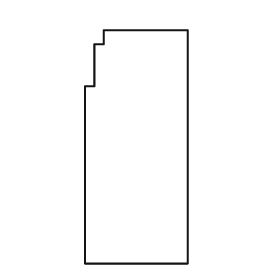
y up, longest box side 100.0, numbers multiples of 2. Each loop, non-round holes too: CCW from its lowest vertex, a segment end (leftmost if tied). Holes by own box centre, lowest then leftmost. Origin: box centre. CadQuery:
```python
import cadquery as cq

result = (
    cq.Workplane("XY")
    .moveTo(-22.0, -50.0)
    .lineTo(22.0, -50.0)
    .lineTo(22.0, 50.0)
    .lineTo(-14.0, 50.0)
    .lineTo(-14.0, 44.0)
    .lineTo(-18.0, 44.0)
    .lineTo(-18.0, 26.0)
    .lineTo(-22.0, 26.0)
    .close()
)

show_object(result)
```